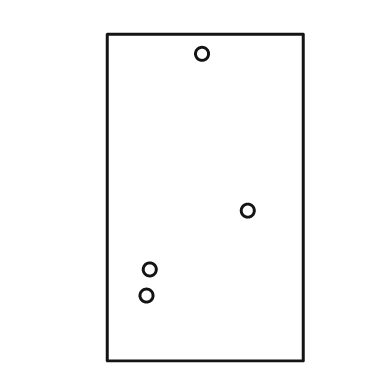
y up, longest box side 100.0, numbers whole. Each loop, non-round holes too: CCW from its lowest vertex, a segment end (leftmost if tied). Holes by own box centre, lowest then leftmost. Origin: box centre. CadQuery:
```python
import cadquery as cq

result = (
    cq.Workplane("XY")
    .moveTo(-30.0, -50.0)
    .lineTo(30.0, -50.0)
    .lineTo(30.0, 50.0)
    .lineTo(-30.0, 50.0)
    .close()
    .moveTo(-18.0, -30.0)
    .circle(2.0)
    .moveTo(-17.0, -22.0)
    .circle(2.0)
    .moveTo(13.0, -4.0)
    .circle(2.0)
    .moveTo(-1.0, 44.0)
    .circle(2.0)
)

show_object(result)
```